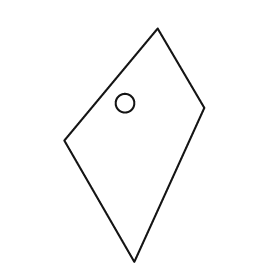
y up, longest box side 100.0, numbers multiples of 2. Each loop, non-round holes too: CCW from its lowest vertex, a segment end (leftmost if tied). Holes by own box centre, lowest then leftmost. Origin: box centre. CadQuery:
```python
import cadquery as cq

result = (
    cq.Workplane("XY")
    .moveTo(0.0, -50.0)
    .lineTo(30.0, 16.0)
    .lineTo(10.0, 50.0)
    .lineTo(-30.0, 2.0)
    .close()
    .moveTo(-4.0, 18.0)
    .circle(4.0)
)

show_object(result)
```